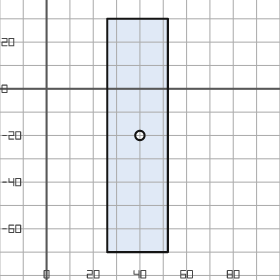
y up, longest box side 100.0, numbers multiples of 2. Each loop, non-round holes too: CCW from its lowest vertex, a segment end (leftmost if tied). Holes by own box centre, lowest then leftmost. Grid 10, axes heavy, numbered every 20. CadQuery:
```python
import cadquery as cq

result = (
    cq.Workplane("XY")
    .moveTo(26.0, -70.0)
    .lineTo(52.0, -70.0)
    .lineTo(52.0, 30.0)
    .lineTo(26.0, 30.0)
    .close()
    .moveTo(40.0, -20.0)
    .circle(2.0)
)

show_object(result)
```